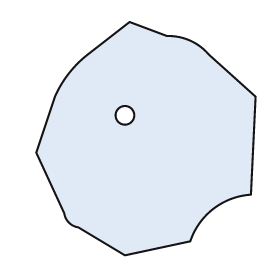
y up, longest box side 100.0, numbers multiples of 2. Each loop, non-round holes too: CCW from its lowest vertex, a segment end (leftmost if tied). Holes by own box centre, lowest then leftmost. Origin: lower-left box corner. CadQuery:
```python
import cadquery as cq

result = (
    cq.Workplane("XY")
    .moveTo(38.0, 0.0)
    .lineTo(66.0, 6.0)
    .threePointArc((76.0, 20.0), (92.0, 26.0))
    .lineTo(94.0, 68.0)
    .lineTo(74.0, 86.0)
    .threePointArc((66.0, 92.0), (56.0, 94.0))
    .lineTo(40.0, 100.0)
    .lineTo(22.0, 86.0)
    .threePointArc((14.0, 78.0), (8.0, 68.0))
    .lineTo(0.0, 44.0)
    .lineTo(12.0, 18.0)
    .threePointArc((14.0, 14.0), (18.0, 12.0))
    .close()
    .moveTo(38.0, 60.0)
    .circle(4.0)
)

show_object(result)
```